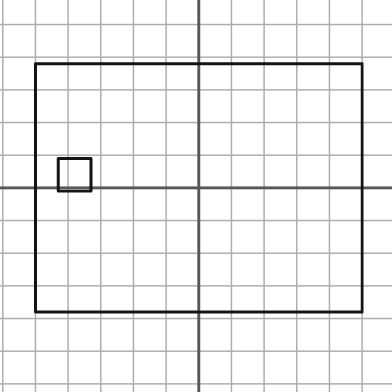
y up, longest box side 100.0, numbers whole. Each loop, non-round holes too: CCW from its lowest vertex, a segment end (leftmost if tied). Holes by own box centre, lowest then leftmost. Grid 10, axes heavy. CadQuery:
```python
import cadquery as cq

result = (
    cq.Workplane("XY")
    .moveTo(-50.0, -38.0)
    .lineTo(50.0, -38.0)
    .lineTo(50.0, 38.0)
    .lineTo(-50.0, 38.0)
    .close()
    .moveTo(-43.0, -1.0)
    .lineTo(-33.0, -1.0)
    .lineTo(-33.0, 9.0)
    .lineTo(-43.0, 9.0)
    .close()
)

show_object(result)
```